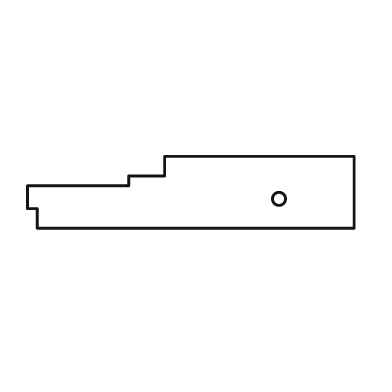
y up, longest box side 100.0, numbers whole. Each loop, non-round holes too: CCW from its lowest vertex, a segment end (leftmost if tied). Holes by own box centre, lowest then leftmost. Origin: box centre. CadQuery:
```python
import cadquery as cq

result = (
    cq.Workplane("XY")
    .moveTo(-47.0, -11.0)
    .lineTo(50.0, -11.0)
    .lineTo(50.0, 11.0)
    .lineTo(-8.0, 11.0)
    .lineTo(-8.0, 5.0)
    .lineTo(-19.0, 5.0)
    .lineTo(-19.0, 2.0)
    .lineTo(-50.0, 2.0)
    .lineTo(-50.0, -5.0)
    .lineTo(-47.0, -5.0)
    .close()
    .moveTo(27.0, -2.0)
    .circle(2.0)
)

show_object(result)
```